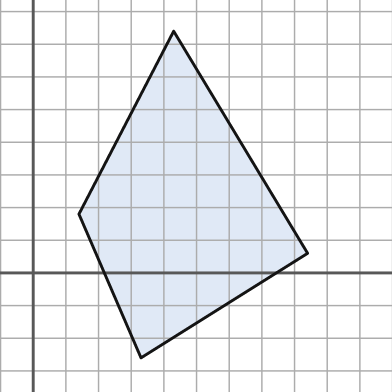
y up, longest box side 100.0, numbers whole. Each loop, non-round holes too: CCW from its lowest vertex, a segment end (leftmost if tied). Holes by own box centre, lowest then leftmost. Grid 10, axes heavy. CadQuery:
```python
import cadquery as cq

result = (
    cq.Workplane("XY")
    .moveTo(33.0, -26.0)
    .lineTo(84.0, 6.0)
    .lineTo(43.0, 74.0)
    .lineTo(14.0, 18.0)
    .close()
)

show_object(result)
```